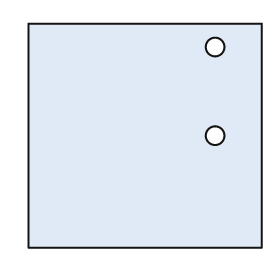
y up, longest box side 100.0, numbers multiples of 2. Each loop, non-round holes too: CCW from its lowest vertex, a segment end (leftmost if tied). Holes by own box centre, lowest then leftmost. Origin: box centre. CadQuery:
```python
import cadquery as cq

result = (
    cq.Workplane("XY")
    .moveTo(-50.0, -48.0)
    .lineTo(50.0, -48.0)
    .lineTo(50.0, 48.0)
    .lineTo(-50.0, 48.0)
    .close()
    .moveTo(30.0, 0.0)
    .circle(4.0)
    .moveTo(30.0, 38.0)
    .circle(4.0)
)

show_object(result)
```